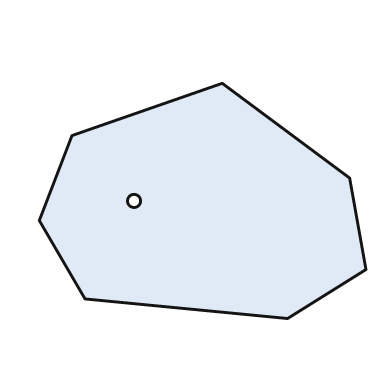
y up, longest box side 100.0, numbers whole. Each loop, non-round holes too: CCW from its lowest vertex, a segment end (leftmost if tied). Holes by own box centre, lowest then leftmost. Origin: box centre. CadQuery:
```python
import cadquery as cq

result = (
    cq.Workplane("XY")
    .moveTo(26.0, -36.0)
    .lineTo(50.0, -21.0)
    .lineTo(45.0, 7.0)
    .lineTo(6.0, 36.0)
    .lineTo(-40.0, 20.0)
    .lineTo(-50.0, -6.0)
    .lineTo(-36.0, -30.0)
    .close()
    .moveTo(-21.0, 0.0)
    .circle(2.0)
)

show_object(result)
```